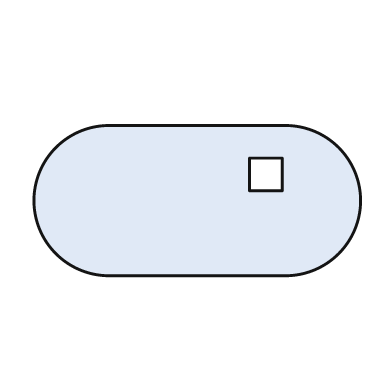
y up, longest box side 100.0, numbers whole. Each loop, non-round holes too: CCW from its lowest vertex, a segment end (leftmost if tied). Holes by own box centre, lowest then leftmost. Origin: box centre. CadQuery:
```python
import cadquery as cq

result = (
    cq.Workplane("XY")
    .moveTo(-27.0, -23.0)
    .lineTo(27.0, -23.0)
    .threePointArc((50.0, 0.0), (27.0, 23.0))
    .lineTo(-27.0, 23.0)
    .threePointArc((-50.0, 0.0), (-27.0, -23.0))
    .close()
    .moveTo(16.0, 3.0)
    .lineTo(26.0, 3.0)
    .lineTo(26.0, 13.0)
    .lineTo(16.0, 13.0)
    .close()
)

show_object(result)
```